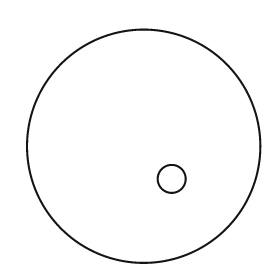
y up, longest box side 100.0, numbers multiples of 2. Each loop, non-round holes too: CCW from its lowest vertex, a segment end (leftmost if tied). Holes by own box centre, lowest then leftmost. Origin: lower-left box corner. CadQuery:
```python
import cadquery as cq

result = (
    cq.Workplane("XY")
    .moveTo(50.0, 50.0)
    .circle(50.0)
    .moveTo(62.0, 36.0)
    .circle(6.0)
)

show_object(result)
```